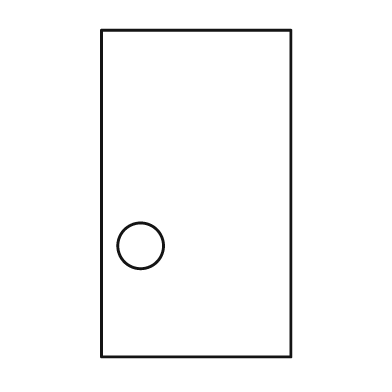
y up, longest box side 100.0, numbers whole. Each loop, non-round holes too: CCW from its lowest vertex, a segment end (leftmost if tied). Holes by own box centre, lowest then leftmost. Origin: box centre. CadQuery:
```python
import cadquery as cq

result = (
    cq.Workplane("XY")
    .moveTo(-29.0, -50.0)
    .lineTo(29.0, -50.0)
    .lineTo(29.0, 50.0)
    .lineTo(-29.0, 50.0)
    .close()
    .moveTo(-17.0, -16.0)
    .circle(7.0)
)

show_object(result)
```